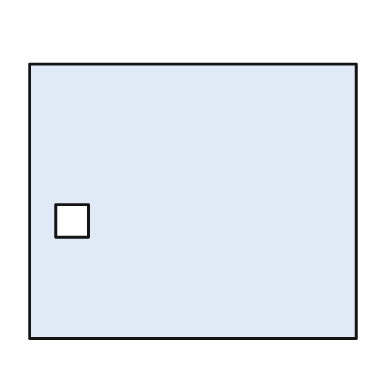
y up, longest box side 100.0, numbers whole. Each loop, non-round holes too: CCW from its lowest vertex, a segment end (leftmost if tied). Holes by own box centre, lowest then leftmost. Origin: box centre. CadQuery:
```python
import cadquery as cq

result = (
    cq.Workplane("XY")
    .moveTo(-50.0, -42.0)
    .lineTo(50.0, -42.0)
    .lineTo(50.0, 42.0)
    .lineTo(-50.0, 42.0)
    .close()
    .moveTo(-42.0, -11.0)
    .lineTo(-32.0, -11.0)
    .lineTo(-32.0, -1.0)
    .lineTo(-42.0, -1.0)
    .close()
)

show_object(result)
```